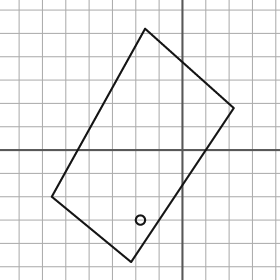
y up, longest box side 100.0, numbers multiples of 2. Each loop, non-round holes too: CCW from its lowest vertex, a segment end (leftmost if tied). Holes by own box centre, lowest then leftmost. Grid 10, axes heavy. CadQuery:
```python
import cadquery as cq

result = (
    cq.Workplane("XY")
    .moveTo(-22.0, -48.0)
    .lineTo(22.0, 18.0)
    .lineTo(-16.0, 52.0)
    .lineTo(-56.0, -20.0)
    .close()
    .moveTo(-18.0, -30.0)
    .circle(2.0)
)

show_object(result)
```